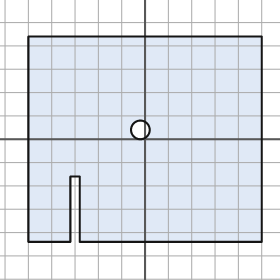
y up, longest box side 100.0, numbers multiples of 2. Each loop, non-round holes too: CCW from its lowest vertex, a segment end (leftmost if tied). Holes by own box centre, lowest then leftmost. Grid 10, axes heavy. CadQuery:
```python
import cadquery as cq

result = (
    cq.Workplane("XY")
    .moveTo(-50.0, -44.0)
    .lineTo(-32.0, -44.0)
    .lineTo(-32.0, -16.0)
    .lineTo(-28.0, -16.0)
    .lineTo(-28.0, -44.0)
    .lineTo(50.0, -44.0)
    .lineTo(50.0, 44.0)
    .lineTo(-50.0, 44.0)
    .close()
    .moveTo(-2.0, 4.0)
    .circle(4.0)
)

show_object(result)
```